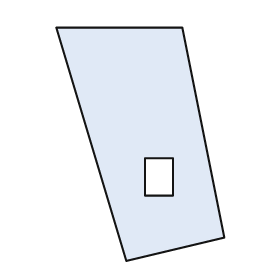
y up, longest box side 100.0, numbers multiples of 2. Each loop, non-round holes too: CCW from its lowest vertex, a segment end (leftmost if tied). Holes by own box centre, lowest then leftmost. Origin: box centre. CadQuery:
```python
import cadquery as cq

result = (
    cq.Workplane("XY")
    .moveTo(-6.0, -50.0)
    .lineTo(36.0, -40.0)
    .lineTo(18.0, 50.0)
    .lineTo(-36.0, 50.0)
    .close()
    .moveTo(2.0, -22.0)
    .lineTo(14.0, -22.0)
    .lineTo(14.0, -6.0)
    .lineTo(2.0, -6.0)
    .close()
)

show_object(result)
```